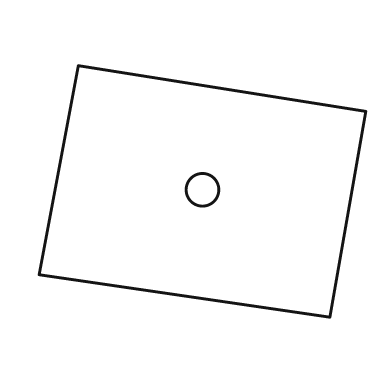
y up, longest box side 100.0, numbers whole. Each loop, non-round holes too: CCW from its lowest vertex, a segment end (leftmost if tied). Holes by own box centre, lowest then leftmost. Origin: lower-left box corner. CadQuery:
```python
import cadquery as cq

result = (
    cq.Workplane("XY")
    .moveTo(89.0, 0.0)
    .lineTo(100.0, 63.0)
    .lineTo(12.0, 77.0)
    .lineTo(0.0, 13.0)
    .close()
    .moveTo(50.0, 39.0)
    .circle(5.0)
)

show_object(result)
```